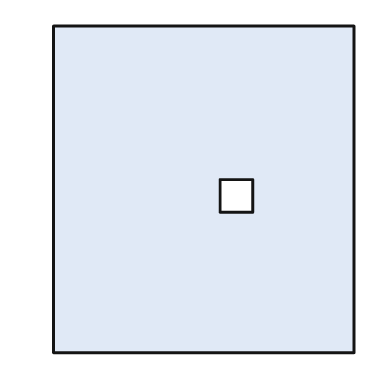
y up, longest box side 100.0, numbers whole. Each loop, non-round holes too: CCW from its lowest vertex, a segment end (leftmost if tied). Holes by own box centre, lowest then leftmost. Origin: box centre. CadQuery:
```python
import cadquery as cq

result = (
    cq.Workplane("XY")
    .moveTo(-46.0, -50.0)
    .lineTo(46.0, -50.0)
    .lineTo(46.0, 50.0)
    .lineTo(-46.0, 50.0)
    .close()
    .moveTo(5.0, -7.0)
    .lineTo(15.0, -7.0)
    .lineTo(15.0, 3.0)
    .lineTo(5.0, 3.0)
    .close()
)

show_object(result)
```